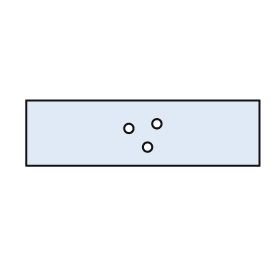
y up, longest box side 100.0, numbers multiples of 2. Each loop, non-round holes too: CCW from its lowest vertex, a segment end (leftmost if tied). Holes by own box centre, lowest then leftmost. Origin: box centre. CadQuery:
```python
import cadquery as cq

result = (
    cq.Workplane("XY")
    .moveTo(-50.0, -14.0)
    .lineTo(50.0, -14.0)
    .lineTo(50.0, 14.0)
    .lineTo(-50.0, 14.0)
    .close()
    .moveTo(2.0, -6.0)
    .circle(2.0)
    .moveTo(-6.0, 2.0)
    .circle(2.0)
    .moveTo(6.0, 4.0)
    .circle(2.0)
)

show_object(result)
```